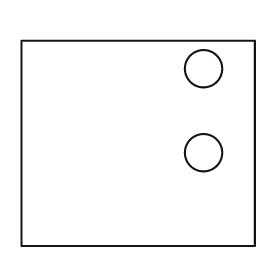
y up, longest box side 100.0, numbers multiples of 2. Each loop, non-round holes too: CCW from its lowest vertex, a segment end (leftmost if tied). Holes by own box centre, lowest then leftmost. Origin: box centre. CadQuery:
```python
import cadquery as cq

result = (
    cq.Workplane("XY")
    .moveTo(-50.0, -44.0)
    .lineTo(50.0, -44.0)
    .lineTo(50.0, 44.0)
    .lineTo(-50.0, 44.0)
    .close()
    .moveTo(28.0, -4.0)
    .circle(8.0)
    .moveTo(28.0, 32.0)
    .circle(8.0)
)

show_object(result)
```